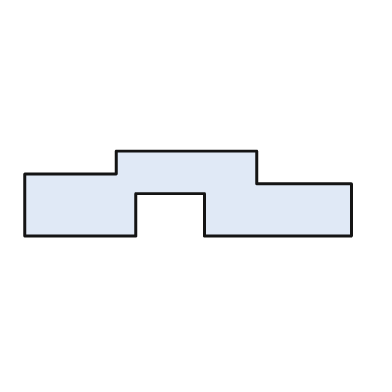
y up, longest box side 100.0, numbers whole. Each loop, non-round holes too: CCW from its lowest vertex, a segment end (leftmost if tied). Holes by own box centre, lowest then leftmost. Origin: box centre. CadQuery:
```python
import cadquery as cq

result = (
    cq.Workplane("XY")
    .moveTo(-50.0, -13.0)
    .lineTo(-16.0, -13.0)
    .lineTo(-16.0, 0.0)
    .lineTo(5.0, 0.0)
    .lineTo(5.0, -13.0)
    .lineTo(50.0, -13.0)
    .lineTo(50.0, 3.0)
    .lineTo(21.0, 3.0)
    .lineTo(21.0, 13.0)
    .lineTo(-22.0, 13.0)
    .lineTo(-22.0, 6.0)
    .lineTo(-50.0, 6.0)
    .close()
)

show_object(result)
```